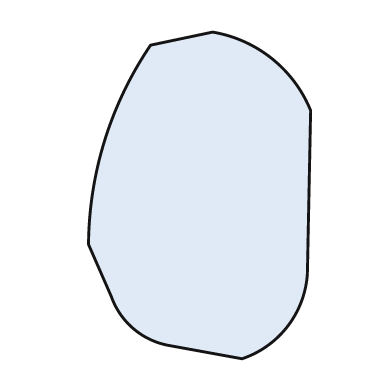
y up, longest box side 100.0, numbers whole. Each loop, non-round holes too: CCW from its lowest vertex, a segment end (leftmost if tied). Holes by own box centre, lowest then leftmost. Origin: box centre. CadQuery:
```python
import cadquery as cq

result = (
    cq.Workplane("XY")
    .moveTo(13.0, -50.0)
    .threePointArc((27.0, -40.0), (33.0, -24.0))
    .lineTo(34.0, 26.0)
    .threePointArc((22.0, 42.0), (4.0, 50.0))
    .lineTo(-15.0, 46.0)
    .threePointArc((-29.0, 17.0), (-34.0, -15.0))
    .lineTo(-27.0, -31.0)
    .threePointArc((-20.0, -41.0), (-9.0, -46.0))
    .close()
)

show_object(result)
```